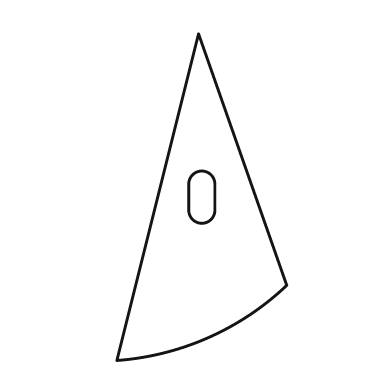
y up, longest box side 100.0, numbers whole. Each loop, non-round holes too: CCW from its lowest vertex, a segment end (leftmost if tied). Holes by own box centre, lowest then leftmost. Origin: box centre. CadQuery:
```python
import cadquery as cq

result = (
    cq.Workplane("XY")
    .moveTo(-26.0, -50.0)
    .threePointArc((2.0, -43.0), (26.0, -27.0))
    .lineTo(-1.0, 50.0)
    .close()
    .moveTo(-4.0, -4.0)
    .threePointArc((0.0, -8.0), (4.0, -4.0))
    .lineTo(4.0, 4.0)
    .threePointArc((0.0, 8.0), (-4.0, 4.0))
    .close()
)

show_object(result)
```